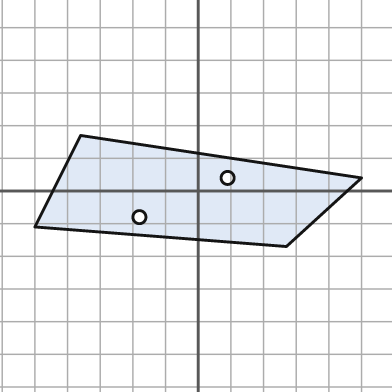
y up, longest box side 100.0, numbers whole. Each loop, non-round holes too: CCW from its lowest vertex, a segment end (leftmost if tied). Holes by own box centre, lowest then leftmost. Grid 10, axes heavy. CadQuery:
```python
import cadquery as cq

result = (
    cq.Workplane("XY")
    .moveTo(27.0, -17.0)
    .lineTo(50.0, 4.0)
    .lineTo(-36.0, 17.0)
    .lineTo(-50.0, -11.0)
    .close()
    .moveTo(-18.0, -8.0)
    .circle(2.0)
    .moveTo(9.0, 4.0)
    .circle(2.0)
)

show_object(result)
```